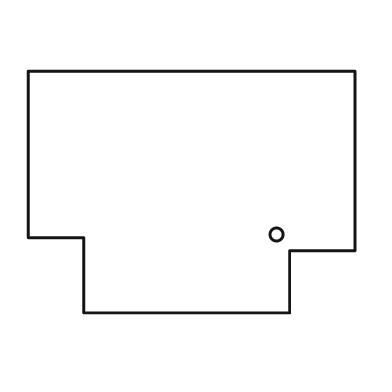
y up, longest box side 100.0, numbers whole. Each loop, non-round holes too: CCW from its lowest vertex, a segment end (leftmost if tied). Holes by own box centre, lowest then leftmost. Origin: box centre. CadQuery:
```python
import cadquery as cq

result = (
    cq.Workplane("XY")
    .moveTo(-33.0, -37.0)
    .lineTo(30.0, -37.0)
    .lineTo(30.0, -18.0)
    .lineTo(50.0, -18.0)
    .lineTo(50.0, 37.0)
    .lineTo(-50.0, 37.0)
    .lineTo(-50.0, -14.0)
    .lineTo(-33.0, -14.0)
    .close()
    .moveTo(26.0, -13.0)
    .circle(2.0)
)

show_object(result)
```